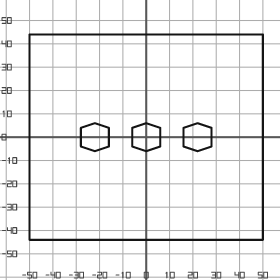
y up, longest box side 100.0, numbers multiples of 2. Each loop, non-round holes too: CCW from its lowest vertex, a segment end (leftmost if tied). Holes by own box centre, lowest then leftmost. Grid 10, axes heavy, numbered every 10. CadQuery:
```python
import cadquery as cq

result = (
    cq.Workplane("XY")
    .moveTo(-50.0, -44.0)
    .lineTo(50.0, -44.0)
    .lineTo(50.0, 44.0)
    .lineTo(-50.0, 44.0)
    .close()
    .moveTo(-22.0, -6.0)
    .lineTo(-16.0, -4.0)
    .lineTo(-16.0, 4.0)
    .lineTo(-22.0, 6.0)
    .lineTo(-28.0, 4.0)
    .lineTo(-28.0, -4.0)
    .close()
    .moveTo(0.0, -6.0)
    .lineTo(6.0, -4.0)
    .lineTo(6.0, 4.0)
    .lineTo(0.0, 6.0)
    .lineTo(-6.0, 4.0)
    .lineTo(-6.0, -4.0)
    .close()
    .moveTo(22.0, -6.0)
    .lineTo(28.0, -4.0)
    .lineTo(28.0, 4.0)
    .lineTo(22.0, 6.0)
    .lineTo(16.0, 4.0)
    .lineTo(16.0, -4.0)
    .close()
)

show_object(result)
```